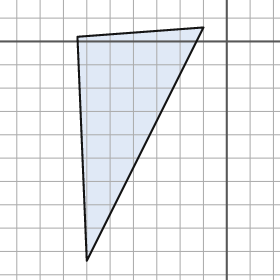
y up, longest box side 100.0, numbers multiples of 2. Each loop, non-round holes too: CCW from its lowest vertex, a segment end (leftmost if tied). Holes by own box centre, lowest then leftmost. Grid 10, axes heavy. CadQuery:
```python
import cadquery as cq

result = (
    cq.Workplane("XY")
    .moveTo(-60.0, -94.0)
    .lineTo(-10.0, 6.0)
    .lineTo(-64.0, 2.0)
    .close()
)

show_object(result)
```